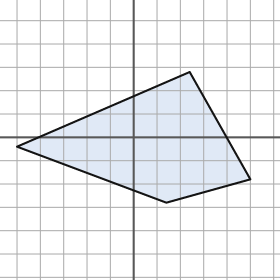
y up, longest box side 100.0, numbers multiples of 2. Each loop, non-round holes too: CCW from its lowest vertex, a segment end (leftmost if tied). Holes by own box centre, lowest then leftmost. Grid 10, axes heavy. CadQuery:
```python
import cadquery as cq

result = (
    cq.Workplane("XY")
    .moveTo(14.0, -28.0)
    .lineTo(50.0, -18.0)
    .lineTo(24.0, 28.0)
    .lineTo(-50.0, -4.0)
    .close()
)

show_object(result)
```